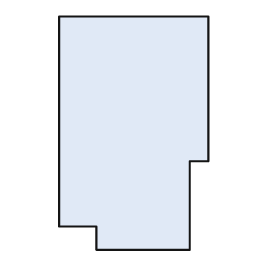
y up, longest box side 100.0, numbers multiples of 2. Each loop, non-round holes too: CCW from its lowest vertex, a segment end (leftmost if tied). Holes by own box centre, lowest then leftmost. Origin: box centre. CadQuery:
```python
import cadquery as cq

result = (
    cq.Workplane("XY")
    .moveTo(-16.0, -50.0)
    .lineTo(24.0, -50.0)
    .lineTo(24.0, -12.0)
    .lineTo(32.0, -12.0)
    .lineTo(32.0, 50.0)
    .lineTo(-32.0, 50.0)
    .lineTo(-32.0, -40.0)
    .lineTo(-16.0, -40.0)
    .close()
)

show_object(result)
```